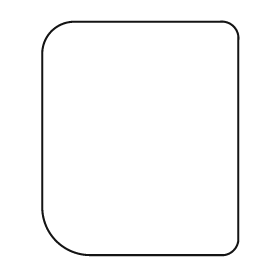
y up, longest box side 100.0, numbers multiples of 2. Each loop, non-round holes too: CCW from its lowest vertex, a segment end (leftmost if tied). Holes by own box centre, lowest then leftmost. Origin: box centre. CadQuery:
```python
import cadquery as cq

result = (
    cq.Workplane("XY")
    .moveTo(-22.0, -50.0)
    .lineTo(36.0, -50.0)
    .threePointArc((40.0, -48.0), (42.0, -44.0))
    .lineTo(42.0, 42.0)
    .threePointArc((40.0, 48.0), (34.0, 50.0))
    .lineTo(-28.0, 50.0)
    .threePointArc((-38.0, 46.0), (-42.0, 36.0))
    .lineTo(-42.0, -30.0)
    .threePointArc((-36.0, -44.0), (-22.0, -50.0))
    .close()
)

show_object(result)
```